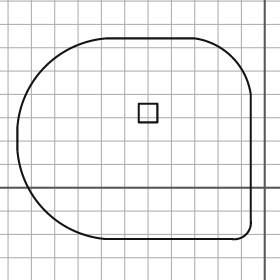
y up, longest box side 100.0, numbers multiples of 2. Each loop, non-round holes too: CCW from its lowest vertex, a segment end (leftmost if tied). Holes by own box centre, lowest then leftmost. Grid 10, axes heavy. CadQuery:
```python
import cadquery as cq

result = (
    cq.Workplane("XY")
    .moveTo(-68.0, -22.0)
    .lineTo(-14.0, -22.0)
    .threePointArc((-8.0, -20.0), (-6.0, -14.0))
    .lineTo(-6.0, 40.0)
    .threePointArc((-14.0, 56.0), (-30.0, 64.0))
    .lineTo(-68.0, 64.0)
    .threePointArc((-94.0, 52.0), (-106.0, 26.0))
    .lineTo(-106.0, 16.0)
    .threePointArc((-94.0, -10.0), (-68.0, -22.0))
    .close()
    .moveTo(-54.0, 28.0)
    .lineTo(-46.0, 28.0)
    .lineTo(-46.0, 36.0)
    .lineTo(-54.0, 36.0)
    .close()
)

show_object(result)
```